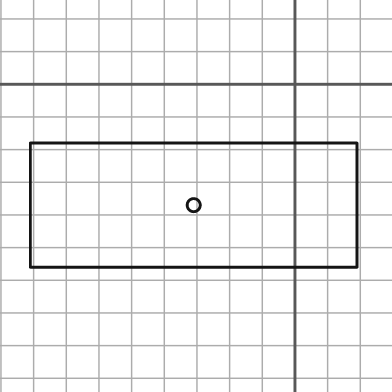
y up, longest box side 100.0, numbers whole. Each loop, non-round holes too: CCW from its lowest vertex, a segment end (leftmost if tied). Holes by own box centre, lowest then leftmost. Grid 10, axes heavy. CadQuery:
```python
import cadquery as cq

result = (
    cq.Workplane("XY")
    .moveTo(-81.0, -56.0)
    .lineTo(19.0, -56.0)
    .lineTo(19.0, -18.0)
    .lineTo(-81.0, -18.0)
    .close()
    .moveTo(-31.0, -37.0)
    .circle(2.0)
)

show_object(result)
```